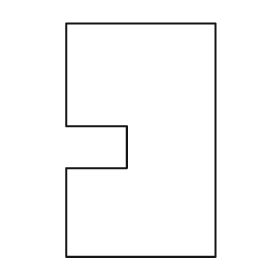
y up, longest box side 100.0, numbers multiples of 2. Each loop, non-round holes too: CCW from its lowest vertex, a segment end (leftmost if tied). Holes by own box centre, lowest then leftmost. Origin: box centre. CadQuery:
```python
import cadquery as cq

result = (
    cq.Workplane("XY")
    .moveTo(-32.0, -50.0)
    .lineTo(32.0, -50.0)
    .lineTo(32.0, 50.0)
    .lineTo(-32.0, 50.0)
    .lineTo(-32.0, 6.0)
    .lineTo(-6.0, 6.0)
    .lineTo(-6.0, -12.0)
    .lineTo(-32.0, -12.0)
    .close()
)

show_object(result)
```